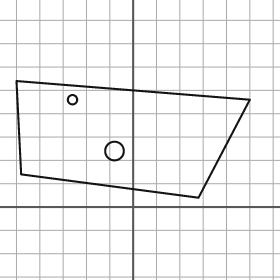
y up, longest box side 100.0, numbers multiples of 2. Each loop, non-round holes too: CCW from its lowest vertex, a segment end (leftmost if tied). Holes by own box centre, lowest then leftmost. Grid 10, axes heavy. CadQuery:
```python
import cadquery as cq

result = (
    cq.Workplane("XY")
    .moveTo(28.0, 4.0)
    .lineTo(50.0, 46.0)
    .lineTo(-50.0, 54.0)
    .lineTo(-48.0, 14.0)
    .close()
    .moveTo(-8.0, 24.0)
    .circle(4.0)
    .moveTo(-26.0, 46.0)
    .circle(2.0)
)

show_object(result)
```